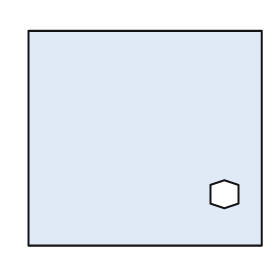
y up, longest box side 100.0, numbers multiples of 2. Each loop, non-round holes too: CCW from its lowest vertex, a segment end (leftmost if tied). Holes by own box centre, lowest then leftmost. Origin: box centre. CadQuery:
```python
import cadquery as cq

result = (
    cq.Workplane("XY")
    .moveTo(-50.0, -46.0)
    .lineTo(50.0, -46.0)
    .lineTo(50.0, 46.0)
    .lineTo(-50.0, 46.0)
    .close()
    .moveTo(34.0, -30.0)
    .lineTo(40.0, -28.0)
    .lineTo(40.0, -20.0)
    .lineTo(34.0, -18.0)
    .lineTo(28.0, -20.0)
    .lineTo(28.0, -28.0)
    .close()
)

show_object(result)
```